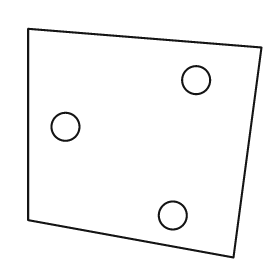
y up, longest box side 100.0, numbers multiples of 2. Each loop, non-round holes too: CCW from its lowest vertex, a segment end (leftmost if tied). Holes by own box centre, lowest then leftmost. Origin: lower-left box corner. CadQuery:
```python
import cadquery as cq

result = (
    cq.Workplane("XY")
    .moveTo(88.0, 0.0)
    .lineTo(100.0, 90.0)
    .lineTo(0.0, 98.0)
    .lineTo(0.0, 16.0)
    .close()
    .moveTo(62.0, 18.0)
    .circle(6.0)
    .moveTo(16.0, 56.0)
    .circle(6.0)
    .moveTo(72.0, 76.0)
    .circle(6.0)
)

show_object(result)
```